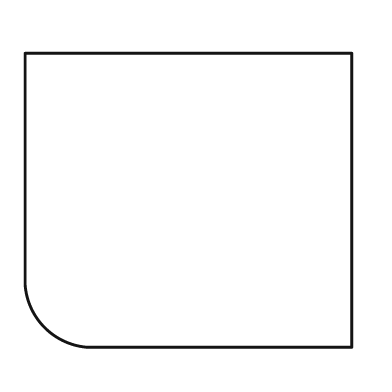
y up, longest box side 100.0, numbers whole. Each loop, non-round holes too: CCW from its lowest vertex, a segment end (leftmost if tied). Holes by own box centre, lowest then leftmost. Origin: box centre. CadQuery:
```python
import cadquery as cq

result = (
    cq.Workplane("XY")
    .moveTo(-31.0, -45.0)
    .lineTo(50.0, -45.0)
    .lineTo(50.0, 45.0)
    .lineTo(-50.0, 45.0)
    .lineTo(-50.0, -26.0)
    .threePointArc((-44.0, -39.0), (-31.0, -45.0))
    .close()
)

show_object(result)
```